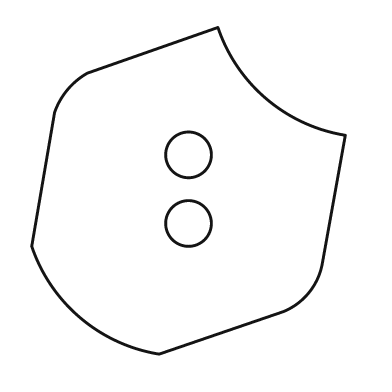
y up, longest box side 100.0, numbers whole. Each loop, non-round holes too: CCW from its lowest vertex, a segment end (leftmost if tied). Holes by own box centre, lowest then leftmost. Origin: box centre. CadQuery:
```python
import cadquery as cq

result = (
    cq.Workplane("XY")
    .moveTo(-9.0, -50.0)
    .lineTo(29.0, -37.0)
    .threePointArc((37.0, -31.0), (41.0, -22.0))
    .lineTo(48.0, 17.0)
    .threePointArc((24.0, 28.0), (9.0, 50.0))
    .lineTo(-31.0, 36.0)
    .threePointArc((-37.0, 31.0), (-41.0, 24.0))
    .lineTo(-48.0, -17.0)
    .threePointArc((-33.0, -39.0), (-9.0, -50.0))
    .close()
    .moveTo(0.0, -10.0)
    .circle(7.0)
    .moveTo(0.0, 11.0)
    .circle(7.0)
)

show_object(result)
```